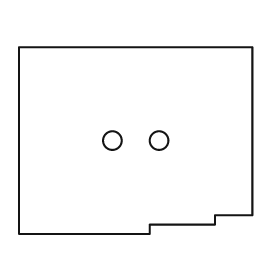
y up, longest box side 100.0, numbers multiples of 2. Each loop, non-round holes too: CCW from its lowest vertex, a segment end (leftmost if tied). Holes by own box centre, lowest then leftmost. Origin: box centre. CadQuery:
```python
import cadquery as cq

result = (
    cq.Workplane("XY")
    .moveTo(-50.0, -40.0)
    .lineTo(6.0, -40.0)
    .lineTo(6.0, -36.0)
    .lineTo(34.0, -36.0)
    .lineTo(34.0, -32.0)
    .lineTo(50.0, -32.0)
    .lineTo(50.0, 40.0)
    .lineTo(-50.0, 40.0)
    .close()
    .moveTo(-10.0, 0.0)
    .circle(4.0)
    .moveTo(10.0, 0.0)
    .circle(4.0)
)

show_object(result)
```